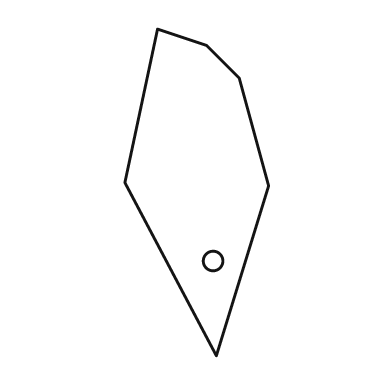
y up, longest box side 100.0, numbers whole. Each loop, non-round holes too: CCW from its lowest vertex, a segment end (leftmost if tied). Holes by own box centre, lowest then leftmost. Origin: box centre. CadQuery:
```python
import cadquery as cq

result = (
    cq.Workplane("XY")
    .moveTo(6.0, -50.0)
    .lineTo(22.0, 2.0)
    .lineTo(13.0, 35.0)
    .lineTo(3.0, 45.0)
    .lineTo(-12.0, 50.0)
    .lineTo(-22.0, 3.0)
    .close()
    .moveTo(5.0, -21.0)
    .circle(3.0)
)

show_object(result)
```